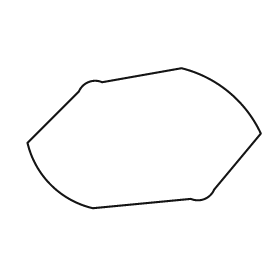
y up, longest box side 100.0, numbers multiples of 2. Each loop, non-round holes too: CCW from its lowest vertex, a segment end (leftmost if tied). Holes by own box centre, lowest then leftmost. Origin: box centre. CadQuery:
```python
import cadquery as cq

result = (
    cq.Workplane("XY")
    .moveTo(-22.0, -30.0)
    .lineTo(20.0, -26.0)
    .threePointArc((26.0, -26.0), (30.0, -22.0))
    .lineTo(50.0, 2.0)
    .threePointArc((36.0, 20.0), (16.0, 30.0))
    .lineTo(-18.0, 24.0)
    .threePointArc((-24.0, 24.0), (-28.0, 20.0))
    .lineTo(-50.0, -2.0)
    .threePointArc((-40.0, -20.0), (-22.0, -30.0))
    .close()
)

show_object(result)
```